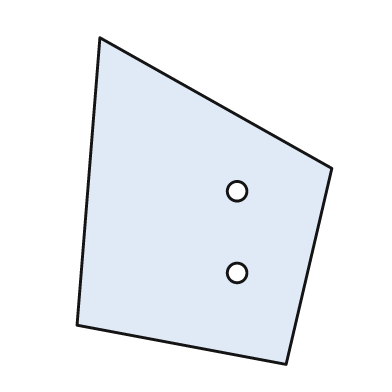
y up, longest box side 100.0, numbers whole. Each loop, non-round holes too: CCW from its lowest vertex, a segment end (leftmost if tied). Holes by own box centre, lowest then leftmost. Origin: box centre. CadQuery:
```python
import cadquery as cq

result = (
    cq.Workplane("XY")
    .moveTo(25.0, -50.0)
    .lineTo(39.0, 10.0)
    .lineTo(-32.0, 50.0)
    .lineTo(-39.0, -38.0)
    .close()
    .moveTo(10.0, -22.0)
    .circle(3.0)
    .moveTo(10.0, 3.0)
    .circle(3.0)
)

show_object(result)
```